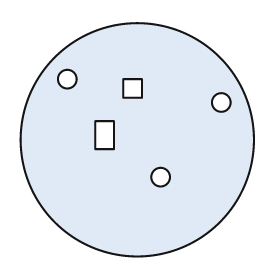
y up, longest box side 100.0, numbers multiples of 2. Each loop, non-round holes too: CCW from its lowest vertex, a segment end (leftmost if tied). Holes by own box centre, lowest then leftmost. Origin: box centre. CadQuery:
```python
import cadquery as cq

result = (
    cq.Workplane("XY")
    .moveTo(0.0, 0.0)
    .circle(50.0)
    .moveTo(10.0, -16.0)
    .circle(4.0)
    .moveTo(-18.0, -4.0)
    .lineTo(-10.0, -4.0)
    .lineTo(-10.0, 8.0)
    .lineTo(-18.0, 8.0)
    .close()
    .moveTo(36.0, 16.0)
    .circle(4.0)
    .moveTo(-6.0, 18.0)
    .lineTo(2.0, 18.0)
    .lineTo(2.0, 26.0)
    .lineTo(-6.0, 26.0)
    .close()
    .moveTo(-30.0, 26.0)
    .circle(4.0)
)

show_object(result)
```